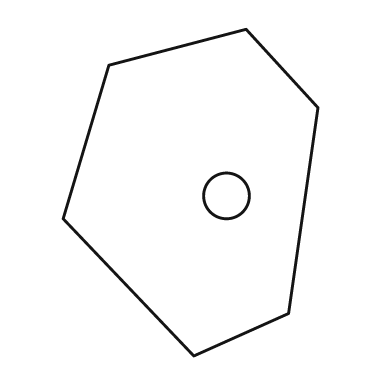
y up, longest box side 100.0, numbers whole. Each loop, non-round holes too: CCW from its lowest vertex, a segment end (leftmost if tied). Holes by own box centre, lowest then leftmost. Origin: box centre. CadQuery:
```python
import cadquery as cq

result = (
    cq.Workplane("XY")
    .moveTo(1.0, -50.0)
    .lineTo(30.0, -37.0)
    .lineTo(39.0, 26.0)
    .lineTo(17.0, 50.0)
    .lineTo(-25.0, 39.0)
    .lineTo(-39.0, -8.0)
    .close()
    .moveTo(11.0, -1.0)
    .circle(7.0)
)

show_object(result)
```